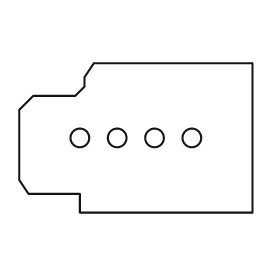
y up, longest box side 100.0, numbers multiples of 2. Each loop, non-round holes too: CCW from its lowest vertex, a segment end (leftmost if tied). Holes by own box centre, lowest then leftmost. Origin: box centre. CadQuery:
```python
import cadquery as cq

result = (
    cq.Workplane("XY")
    .moveTo(-24.0, -32.0)
    .lineTo(50.0, -32.0)
    .lineTo(50.0, 32.0)
    .lineTo(-18.0, 32.0)
    .lineTo(-22.0, 26.0)
    .lineTo(-22.0, 22.0)
    .lineTo(-26.0, 18.0)
    .lineTo(-44.0, 18.0)
    .lineTo(-50.0, 12.0)
    .lineTo(-50.0, -18.0)
    .lineTo(-46.0, -24.0)
    .lineTo(-24.0, -24.0)
    .close()
    .moveTo(-24.0, 0.0)
    .circle(4.0)
    .moveTo(-8.0, 0.0)
    .circle(4.0)
    .moveTo(8.0, 0.0)
    .circle(4.0)
    .moveTo(24.0, 0.0)
    .circle(4.0)
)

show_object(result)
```